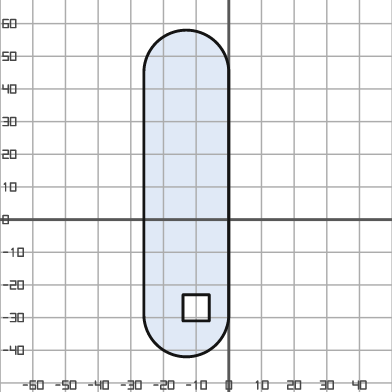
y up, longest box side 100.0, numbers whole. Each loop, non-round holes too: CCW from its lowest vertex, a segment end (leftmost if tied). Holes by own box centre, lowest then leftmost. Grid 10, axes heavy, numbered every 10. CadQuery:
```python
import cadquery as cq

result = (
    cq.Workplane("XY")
    .moveTo(-26.0, -29.0)
    .threePointArc((-13.0, -42.0), (0.0, -29.0))
    .lineTo(0.0, 45.0)
    .threePointArc((-13.0, 58.0), (-26.0, 45.0))
    .close()
    .moveTo(-14.0, -31.0)
    .lineTo(-6.0, -31.0)
    .lineTo(-6.0, -23.0)
    .lineTo(-14.0, -23.0)
    .close()
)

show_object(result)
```